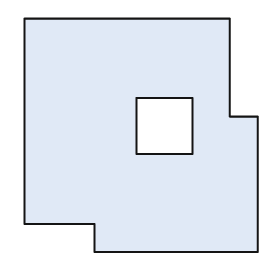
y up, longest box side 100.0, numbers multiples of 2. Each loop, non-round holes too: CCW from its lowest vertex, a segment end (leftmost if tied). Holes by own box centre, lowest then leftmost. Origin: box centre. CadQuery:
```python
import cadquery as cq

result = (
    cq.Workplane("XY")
    .moveTo(-20.0, -50.0)
    .lineTo(50.0, -50.0)
    .lineTo(50.0, 8.0)
    .lineTo(38.0, 8.0)
    .lineTo(38.0, 50.0)
    .lineTo(-50.0, 50.0)
    .lineTo(-50.0, -38.0)
    .lineTo(-20.0, -38.0)
    .close()
    .moveTo(-2.0, -8.0)
    .lineTo(22.0, -8.0)
    .lineTo(22.0, 16.0)
    .lineTo(-2.0, 16.0)
    .close()
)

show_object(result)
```